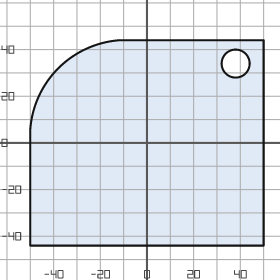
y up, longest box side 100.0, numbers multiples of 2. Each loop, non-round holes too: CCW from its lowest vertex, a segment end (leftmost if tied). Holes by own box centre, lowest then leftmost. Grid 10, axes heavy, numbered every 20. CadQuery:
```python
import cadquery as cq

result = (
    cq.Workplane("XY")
    .moveTo(-50.0, -44.0)
    .lineTo(50.0, -44.0)
    .lineTo(50.0, 44.0)
    .lineTo(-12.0, 44.0)
    .threePointArc((-38.0, 32.0), (-50.0, 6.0))
    .close()
    .moveTo(38.0, 34.0)
    .circle(6.0)
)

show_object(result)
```